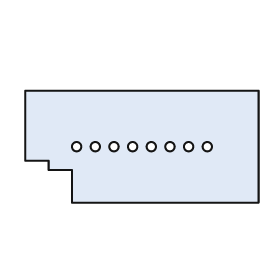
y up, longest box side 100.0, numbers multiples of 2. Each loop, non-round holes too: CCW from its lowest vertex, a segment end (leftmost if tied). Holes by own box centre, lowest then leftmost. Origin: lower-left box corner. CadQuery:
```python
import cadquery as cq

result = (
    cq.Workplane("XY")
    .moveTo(20.0, 0.0)
    .lineTo(100.0, 0.0)
    .lineTo(100.0, 48.0)
    .lineTo(0.0, 48.0)
    .lineTo(0.0, 18.0)
    .lineTo(10.0, 18.0)
    .lineTo(10.0, 14.0)
    .lineTo(20.0, 14.0)
    .close()
    .moveTo(22.0, 24.0)
    .circle(2.0)
    .moveTo(30.0, 24.0)
    .circle(2.0)
    .moveTo(38.0, 24.0)
    .circle(2.0)
    .moveTo(46.0, 24.0)
    .circle(2.0)
    .moveTo(54.0, 24.0)
    .circle(2.0)
    .moveTo(62.0, 24.0)
    .circle(2.0)
    .moveTo(70.0, 24.0)
    .circle(2.0)
    .moveTo(78.0, 24.0)
    .circle(2.0)
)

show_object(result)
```